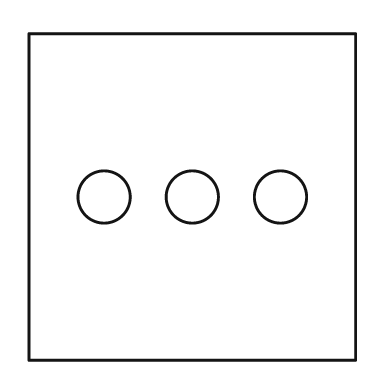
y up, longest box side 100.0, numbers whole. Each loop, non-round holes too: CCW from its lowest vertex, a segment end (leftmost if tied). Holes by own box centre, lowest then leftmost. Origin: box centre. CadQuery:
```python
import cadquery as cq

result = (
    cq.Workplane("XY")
    .moveTo(-50.0, -50.0)
    .lineTo(50.0, -50.0)
    .lineTo(50.0, 50.0)
    .lineTo(-50.0, 50.0)
    .close()
    .moveTo(-27.0, 0.0)
    .circle(8.0)
    .moveTo(0.0, 0.0)
    .circle(8.0)
    .moveTo(27.0, 0.0)
    .circle(8.0)
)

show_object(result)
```